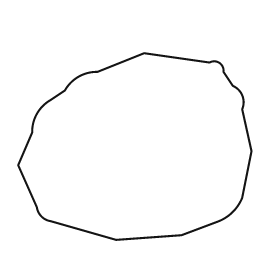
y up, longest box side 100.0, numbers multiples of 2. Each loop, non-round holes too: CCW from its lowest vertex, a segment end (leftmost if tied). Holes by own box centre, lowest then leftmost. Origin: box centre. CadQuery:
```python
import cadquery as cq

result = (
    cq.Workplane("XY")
    .moveTo(-8.0, -40.0)
    .lineTo(20.0, -38.0)
    .lineTo(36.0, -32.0)
    .threePointArc((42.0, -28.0), (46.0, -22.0))
    .lineTo(50.0, -2.0)
    .lineTo(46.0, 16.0)
    .threePointArc((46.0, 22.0), (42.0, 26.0))
    .lineTo(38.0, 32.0)
    .threePointArc((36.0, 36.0), (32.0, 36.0))
    .lineTo(4.0, 40.0)
    .lineTo(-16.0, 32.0)
    .threePointArc((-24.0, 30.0), (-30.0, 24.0))
    .lineTo(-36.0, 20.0)
    .threePointArc((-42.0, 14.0), (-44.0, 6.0))
    .lineTo(-50.0, -8.0)
    .lineTo(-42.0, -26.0)
    .threePointArc((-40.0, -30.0), (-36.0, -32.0))
    .close()
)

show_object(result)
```